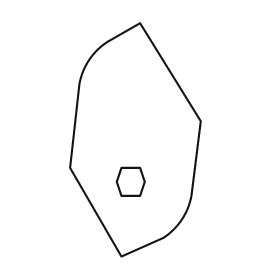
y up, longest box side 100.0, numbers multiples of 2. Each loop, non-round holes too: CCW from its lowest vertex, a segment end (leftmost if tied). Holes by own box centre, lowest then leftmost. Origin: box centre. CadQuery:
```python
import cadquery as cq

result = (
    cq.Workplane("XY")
    .moveTo(-6.0, -50.0)
    .lineTo(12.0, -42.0)
    .threePointArc((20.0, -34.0), (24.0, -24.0))
    .lineTo(28.0, 8.0)
    .lineTo(2.0, 50.0)
    .lineTo(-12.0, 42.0)
    .threePointArc((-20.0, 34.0), (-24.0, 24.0))
    .lineTo(-28.0, -12.0)
    .close()
    .moveTo(-6.0, -24.0)
    .lineTo(2.0, -24.0)
    .lineTo(4.0, -18.0)
    .lineTo(2.0, -12.0)
    .lineTo(-6.0, -12.0)
    .lineTo(-8.0, -18.0)
    .close()
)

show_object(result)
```